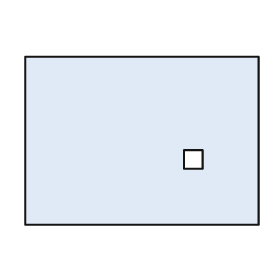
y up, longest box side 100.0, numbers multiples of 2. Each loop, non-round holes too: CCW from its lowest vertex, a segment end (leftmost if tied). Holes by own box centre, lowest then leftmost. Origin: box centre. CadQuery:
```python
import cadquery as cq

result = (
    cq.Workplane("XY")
    .moveTo(-50.0, -36.0)
    .lineTo(50.0, -36.0)
    .lineTo(50.0, 36.0)
    .lineTo(-50.0, 36.0)
    .close()
    .moveTo(18.0, -12.0)
    .lineTo(26.0, -12.0)
    .lineTo(26.0, -4.0)
    .lineTo(18.0, -4.0)
    .close()
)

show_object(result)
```